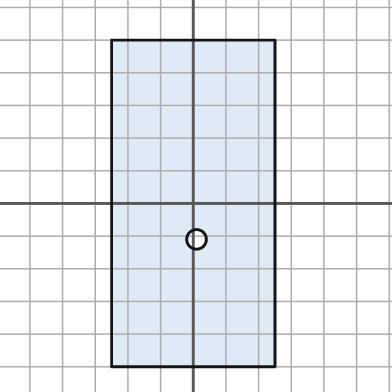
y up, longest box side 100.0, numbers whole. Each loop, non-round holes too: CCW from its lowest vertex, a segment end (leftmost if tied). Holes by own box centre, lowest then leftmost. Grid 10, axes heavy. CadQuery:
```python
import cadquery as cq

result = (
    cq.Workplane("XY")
    .moveTo(-25.0, -50.0)
    .lineTo(25.0, -50.0)
    .lineTo(25.0, 50.0)
    .lineTo(-25.0, 50.0)
    .close()
    .moveTo(1.0, -11.0)
    .circle(3.0)
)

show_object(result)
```